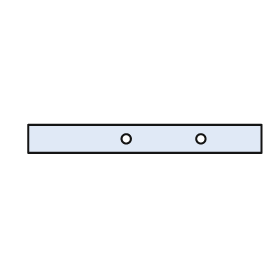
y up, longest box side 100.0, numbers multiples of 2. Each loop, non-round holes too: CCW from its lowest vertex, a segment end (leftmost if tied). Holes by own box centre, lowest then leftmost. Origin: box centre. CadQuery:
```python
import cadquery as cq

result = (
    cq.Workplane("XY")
    .moveTo(-50.0, -6.0)
    .lineTo(50.0, -6.0)
    .lineTo(50.0, 6.0)
    .lineTo(-50.0, 6.0)
    .close()
    .moveTo(-8.0, 0.0)
    .circle(2.0)
    .moveTo(24.0, 0.0)
    .circle(2.0)
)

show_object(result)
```